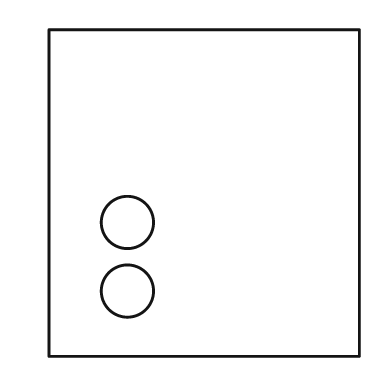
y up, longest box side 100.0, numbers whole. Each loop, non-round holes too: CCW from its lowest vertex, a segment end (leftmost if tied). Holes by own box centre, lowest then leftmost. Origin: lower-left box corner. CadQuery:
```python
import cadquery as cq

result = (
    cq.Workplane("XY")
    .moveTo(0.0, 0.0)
    .lineTo(95.0, 0.0)
    .lineTo(95.0, 100.0)
    .lineTo(0.0, 100.0)
    .close()
    .moveTo(24.0, 20.0)
    .circle(8.0)
    .moveTo(24.0, 41.0)
    .circle(8.0)
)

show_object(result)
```